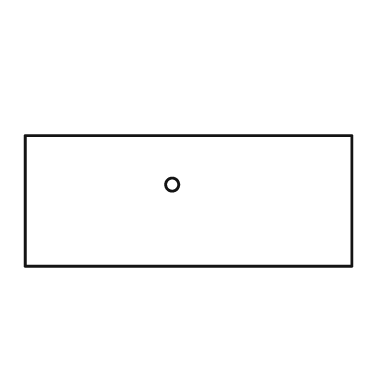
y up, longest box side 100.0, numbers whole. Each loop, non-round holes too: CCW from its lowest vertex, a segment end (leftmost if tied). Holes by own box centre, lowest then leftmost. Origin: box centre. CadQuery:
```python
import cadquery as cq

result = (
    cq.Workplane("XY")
    .moveTo(-50.0, -20.0)
    .lineTo(50.0, -20.0)
    .lineTo(50.0, 20.0)
    .lineTo(-50.0, 20.0)
    .close()
    .moveTo(-5.0, 5.0)
    .circle(2.0)
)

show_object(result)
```